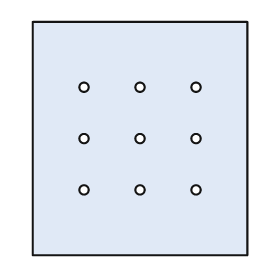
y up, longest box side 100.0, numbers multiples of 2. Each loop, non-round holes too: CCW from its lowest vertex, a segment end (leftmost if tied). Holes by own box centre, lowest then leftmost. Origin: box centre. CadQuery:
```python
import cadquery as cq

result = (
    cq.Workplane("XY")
    .moveTo(-46.0, -50.0)
    .lineTo(46.0, -50.0)
    .lineTo(46.0, 50.0)
    .lineTo(-46.0, 50.0)
    .close()
    .moveTo(-24.0, -22.0)
    .circle(2.0)
    .moveTo(0.0, -22.0)
    .circle(2.0)
    .moveTo(24.0, -22.0)
    .circle(2.0)
    .moveTo(-24.0, 0.0)
    .circle(2.0)
    .moveTo(0.0, 0.0)
    .circle(2.0)
    .moveTo(24.0, 0.0)
    .circle(2.0)
    .moveTo(-24.0, 22.0)
    .circle(2.0)
    .moveTo(0.0, 22.0)
    .circle(2.0)
    .moveTo(24.0, 22.0)
    .circle(2.0)
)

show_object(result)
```